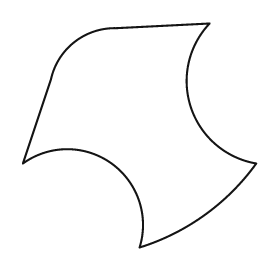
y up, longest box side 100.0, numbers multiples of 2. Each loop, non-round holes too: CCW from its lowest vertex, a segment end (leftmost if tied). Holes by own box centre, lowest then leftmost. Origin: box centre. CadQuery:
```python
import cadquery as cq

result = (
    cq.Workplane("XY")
    .moveTo(0.0, -48.0)
    .threePointArc((28.0, -34.0), (50.0, -12.0))
    .threePointArc((22.0, 12.0), (30.0, 48.0))
    .lineTo(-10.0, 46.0)
    .threePointArc((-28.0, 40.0), (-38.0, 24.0))
    .lineTo(-50.0, -12.0)
    .threePointArc((-12.0, -12.0), (0.0, -48.0))
    .close()
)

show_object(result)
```